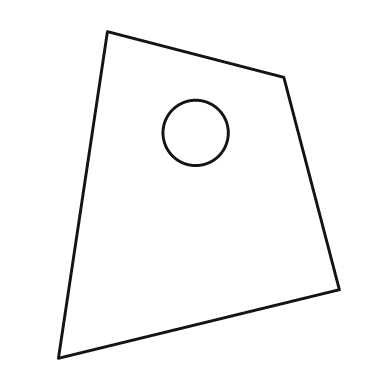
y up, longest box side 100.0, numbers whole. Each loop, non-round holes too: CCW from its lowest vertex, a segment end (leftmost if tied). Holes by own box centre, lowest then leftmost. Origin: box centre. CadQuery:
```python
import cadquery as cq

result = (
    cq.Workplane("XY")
    .moveTo(-43.0, -50.0)
    .lineTo(43.0, -29.0)
    .lineTo(26.0, 36.0)
    .lineTo(-28.0, 50.0)
    .close()
    .moveTo(-1.0, 19.0)
    .circle(10.0)
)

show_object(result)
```